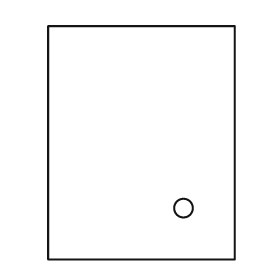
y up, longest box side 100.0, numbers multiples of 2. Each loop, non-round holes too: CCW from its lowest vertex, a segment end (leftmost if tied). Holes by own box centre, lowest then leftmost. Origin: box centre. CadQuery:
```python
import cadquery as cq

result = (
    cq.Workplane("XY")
    .moveTo(-40.0, -50.0)
    .lineTo(40.0, -50.0)
    .lineTo(40.0, 50.0)
    .lineTo(-40.0, 50.0)
    .close()
    .moveTo(18.0, -28.0)
    .circle(4.0)
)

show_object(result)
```